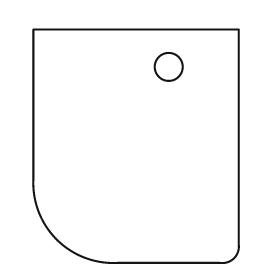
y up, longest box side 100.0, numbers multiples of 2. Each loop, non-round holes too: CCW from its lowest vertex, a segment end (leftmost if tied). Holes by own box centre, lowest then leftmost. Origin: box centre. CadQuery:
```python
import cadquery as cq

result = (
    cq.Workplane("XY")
    .moveTo(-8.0, -50.0)
    .lineTo(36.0, -50.0)
    .threePointArc((42.0, -48.0), (44.0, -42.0))
    .lineTo(44.0, 50.0)
    .lineTo(-44.0, 50.0)
    .lineTo(-44.0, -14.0)
    .threePointArc((-34.0, -40.0), (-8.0, -50.0))
    .close()
    .moveTo(14.0, 34.0)
    .circle(6.0)
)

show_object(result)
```